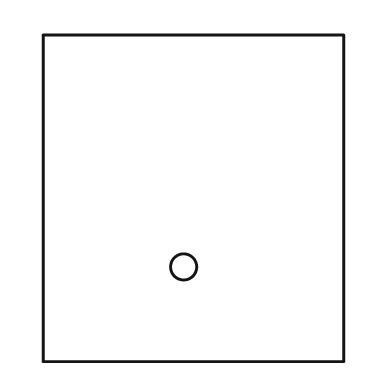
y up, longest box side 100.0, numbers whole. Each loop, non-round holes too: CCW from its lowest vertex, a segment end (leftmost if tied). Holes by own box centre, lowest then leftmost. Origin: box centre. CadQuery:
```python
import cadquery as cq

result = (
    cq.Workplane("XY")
    .moveTo(-46.0, -50.0)
    .lineTo(46.0, -50.0)
    .lineTo(46.0, 50.0)
    .lineTo(-46.0, 50.0)
    .close()
    .moveTo(-3.0, -21.0)
    .circle(4.0)
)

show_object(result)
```